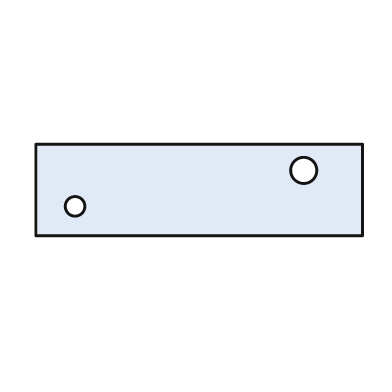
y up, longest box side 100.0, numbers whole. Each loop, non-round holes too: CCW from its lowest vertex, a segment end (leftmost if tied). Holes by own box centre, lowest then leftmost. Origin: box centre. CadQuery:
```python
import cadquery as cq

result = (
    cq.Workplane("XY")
    .moveTo(-50.0, -14.0)
    .lineTo(50.0, -14.0)
    .lineTo(50.0, 14.0)
    .lineTo(-50.0, 14.0)
    .close()
    .moveTo(-38.0, -5.0)
    .circle(3.0)
    .moveTo(32.0, 6.0)
    .circle(4.0)
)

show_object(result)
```